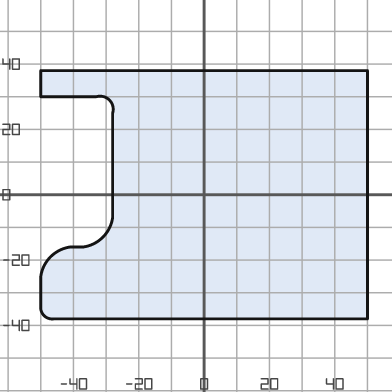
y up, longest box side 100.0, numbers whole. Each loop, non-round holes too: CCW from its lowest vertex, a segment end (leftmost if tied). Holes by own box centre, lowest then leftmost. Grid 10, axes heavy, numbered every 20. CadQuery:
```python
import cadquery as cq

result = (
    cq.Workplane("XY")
    .moveTo(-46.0, -38.0)
    .lineTo(50.0, -38.0)
    .lineTo(50.0, 38.0)
    .lineTo(-50.0, 38.0)
    .lineTo(-50.0, 30.0)
    .lineTo(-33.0, 30.0)
    .threePointArc((-29.0, 29.0), (-28.0, 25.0))
    .lineTo(-28.0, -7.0)
    .threePointArc((-31.0, -13.0), (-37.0, -16.0))
    .lineTo(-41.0, -16.0)
    .threePointArc((-47.0, -19.0), (-50.0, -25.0))
    .lineTo(-50.0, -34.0)
    .threePointArc((-49.0, -37.0), (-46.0, -38.0))
    .close()
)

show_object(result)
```